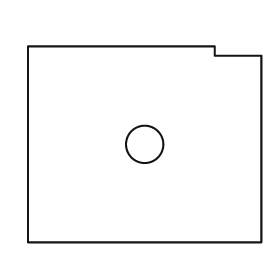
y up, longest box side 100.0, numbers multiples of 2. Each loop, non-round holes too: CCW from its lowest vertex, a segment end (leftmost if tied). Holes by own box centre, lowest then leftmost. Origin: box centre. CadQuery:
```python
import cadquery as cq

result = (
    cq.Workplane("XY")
    .moveTo(-50.0, -42.0)
    .lineTo(50.0, -42.0)
    .lineTo(50.0, 38.0)
    .lineTo(30.0, 38.0)
    .lineTo(30.0, 42.0)
    .lineTo(-50.0, 42.0)
    .close()
    .moveTo(0.0, 0.0)
    .circle(8.0)
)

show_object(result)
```